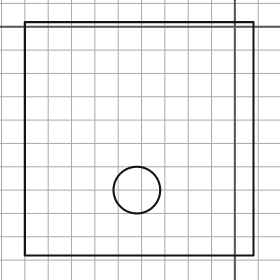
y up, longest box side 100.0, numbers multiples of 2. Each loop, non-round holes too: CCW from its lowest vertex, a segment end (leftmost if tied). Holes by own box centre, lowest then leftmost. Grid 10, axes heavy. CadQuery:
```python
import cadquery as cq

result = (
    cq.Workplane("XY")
    .moveTo(-90.0, -98.0)
    .lineTo(8.0, -98.0)
    .lineTo(8.0, 2.0)
    .lineTo(-90.0, 2.0)
    .close()
    .moveTo(-42.0, -70.0)
    .circle(10.0)
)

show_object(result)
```